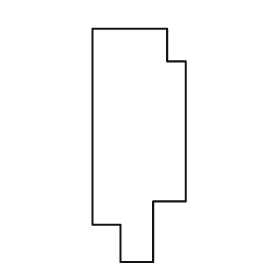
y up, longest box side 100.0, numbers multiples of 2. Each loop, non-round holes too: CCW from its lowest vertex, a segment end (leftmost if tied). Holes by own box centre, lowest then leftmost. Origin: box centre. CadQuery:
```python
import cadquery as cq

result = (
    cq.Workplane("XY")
    .moveTo(-8.0, -50.0)
    .lineTo(6.0, -50.0)
    .lineTo(6.0, -24.0)
    .lineTo(20.0, -24.0)
    .lineTo(20.0, 36.0)
    .lineTo(12.0, 36.0)
    .lineTo(12.0, 50.0)
    .lineTo(-20.0, 50.0)
    .lineTo(-20.0, -34.0)
    .lineTo(-8.0, -34.0)
    .close()
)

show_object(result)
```